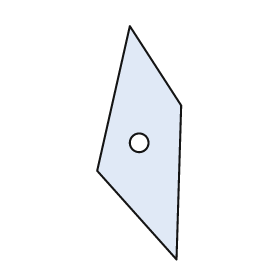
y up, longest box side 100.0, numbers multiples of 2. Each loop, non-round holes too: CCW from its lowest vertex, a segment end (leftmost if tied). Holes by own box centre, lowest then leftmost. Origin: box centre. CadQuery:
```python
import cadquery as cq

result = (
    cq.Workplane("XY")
    .moveTo(16.0, -50.0)
    .lineTo(18.0, 16.0)
    .lineTo(-4.0, 50.0)
    .lineTo(-18.0, -12.0)
    .close()
    .moveTo(0.0, 0.0)
    .circle(4.0)
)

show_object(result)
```